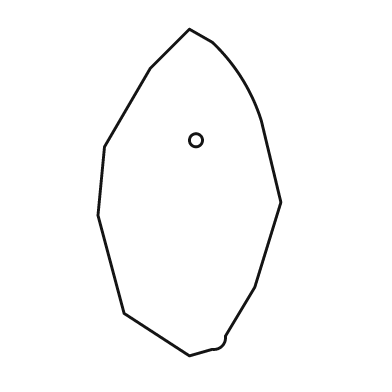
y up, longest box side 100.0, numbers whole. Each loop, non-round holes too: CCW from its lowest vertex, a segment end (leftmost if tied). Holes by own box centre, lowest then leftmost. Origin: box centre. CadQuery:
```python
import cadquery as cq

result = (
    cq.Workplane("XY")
    .moveTo(0.0, -50.0)
    .lineTo(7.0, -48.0)
    .threePointArc((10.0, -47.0), (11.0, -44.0))
    .lineTo(20.0, -29.0)
    .lineTo(28.0, -3.0)
    .lineTo(22.0, 22.0)
    .threePointArc((16.0, 35.0), (7.0, 46.0))
    .lineTo(0.0, 50.0)
    .lineTo(-12.0, 38.0)
    .lineTo(-26.0, 14.0)
    .lineTo(-28.0, -7.0)
    .lineTo(-20.0, -37.0)
    .close()
    .moveTo(2.0, 16.0)
    .circle(2.0)
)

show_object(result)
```